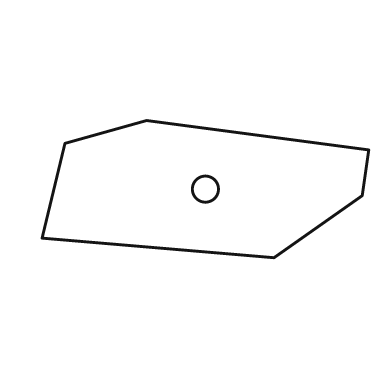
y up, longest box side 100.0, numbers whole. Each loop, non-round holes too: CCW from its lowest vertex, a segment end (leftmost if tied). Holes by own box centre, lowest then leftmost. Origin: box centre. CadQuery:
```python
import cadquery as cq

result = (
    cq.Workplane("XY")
    .moveTo(21.0, -21.0)
    .lineTo(48.0, -2.0)
    .lineTo(50.0, 12.0)
    .lineTo(-18.0, 21.0)
    .lineTo(-43.0, 14.0)
    .lineTo(-50.0, -15.0)
    .close()
    .moveTo(0.0, 0.0)
    .circle(4.0)
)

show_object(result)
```